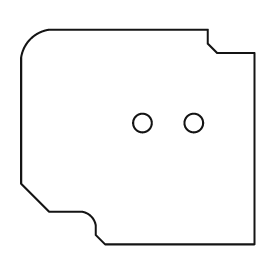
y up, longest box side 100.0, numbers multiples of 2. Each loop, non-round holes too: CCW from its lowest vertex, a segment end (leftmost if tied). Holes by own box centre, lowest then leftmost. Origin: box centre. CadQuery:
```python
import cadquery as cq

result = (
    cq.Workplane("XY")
    .moveTo(-14.0, -46.0)
    .lineTo(50.0, -46.0)
    .lineTo(50.0, 36.0)
    .lineTo(34.0, 36.0)
    .lineTo(30.0, 40.0)
    .lineTo(30.0, 46.0)
    .lineTo(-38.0, 46.0)
    .threePointArc((-46.0, 42.0), (-50.0, 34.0))
    .lineTo(-50.0, -20.0)
    .lineTo(-38.0, -32.0)
    .lineTo(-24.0, -32.0)
    .threePointArc((-20.0, -34.0), (-18.0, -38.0))
    .lineTo(-18.0, -42.0)
    .close()
    .moveTo(2.0, 6.0)
    .circle(4.0)
    .moveTo(24.0, 6.0)
    .circle(4.0)
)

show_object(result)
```